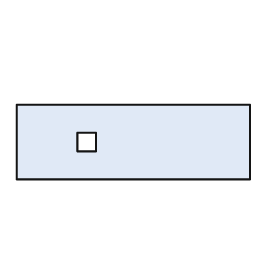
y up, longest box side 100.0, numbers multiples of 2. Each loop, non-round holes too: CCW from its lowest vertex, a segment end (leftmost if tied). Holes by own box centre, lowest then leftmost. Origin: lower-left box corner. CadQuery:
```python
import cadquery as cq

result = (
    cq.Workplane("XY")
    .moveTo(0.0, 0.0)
    .lineTo(100.0, 0.0)
    .lineTo(100.0, 32.0)
    .lineTo(0.0, 32.0)
    .close()
    .moveTo(26.0, 12.0)
    .lineTo(34.0, 12.0)
    .lineTo(34.0, 20.0)
    .lineTo(26.0, 20.0)
    .close()
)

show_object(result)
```